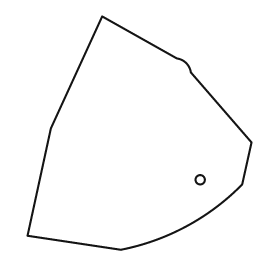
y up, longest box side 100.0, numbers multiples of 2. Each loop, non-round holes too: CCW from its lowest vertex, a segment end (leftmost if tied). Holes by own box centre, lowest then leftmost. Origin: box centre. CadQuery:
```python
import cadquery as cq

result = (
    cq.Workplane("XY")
    .moveTo(-8.0, -50.0)
    .threePointArc((20.0, -40.0), (44.0, -22.0))
    .lineTo(48.0, -4.0)
    .lineTo(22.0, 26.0)
    .threePointArc((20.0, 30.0), (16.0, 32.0))
    .lineTo(-16.0, 50.0)
    .lineTo(-38.0, 2.0)
    .lineTo(-48.0, -44.0)
    .close()
    .moveTo(26.0, -20.0)
    .circle(2.0)
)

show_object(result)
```